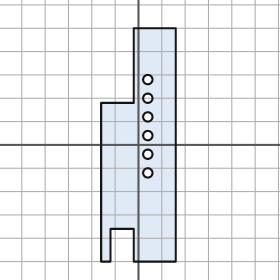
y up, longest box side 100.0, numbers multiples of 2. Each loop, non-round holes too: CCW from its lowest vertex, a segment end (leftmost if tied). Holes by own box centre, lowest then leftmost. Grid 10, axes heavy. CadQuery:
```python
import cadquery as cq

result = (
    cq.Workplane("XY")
    .moveTo(-16.0, -50.0)
    .lineTo(-12.0, -50.0)
    .lineTo(-12.0, -36.0)
    .lineTo(-2.0, -36.0)
    .lineTo(-2.0, -50.0)
    .lineTo(16.0, -50.0)
    .lineTo(16.0, 50.0)
    .lineTo(-2.0, 50.0)
    .lineTo(-2.0, 18.0)
    .lineTo(-16.0, 18.0)
    .close()
    .moveTo(4.0, -12.0)
    .circle(2.0)
    .moveTo(4.0, -4.0)
    .circle(2.0)
    .moveTo(4.0, 4.0)
    .circle(2.0)
    .moveTo(4.0, 12.0)
    .circle(2.0)
    .moveTo(4.0, 20.0)
    .circle(2.0)
    .moveTo(4.0, 28.0)
    .circle(2.0)
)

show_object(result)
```